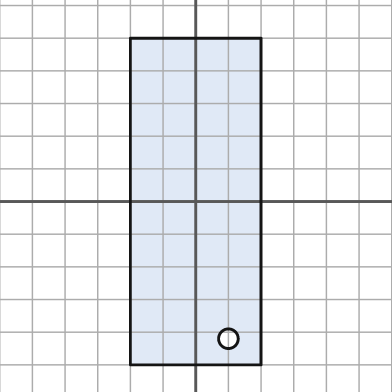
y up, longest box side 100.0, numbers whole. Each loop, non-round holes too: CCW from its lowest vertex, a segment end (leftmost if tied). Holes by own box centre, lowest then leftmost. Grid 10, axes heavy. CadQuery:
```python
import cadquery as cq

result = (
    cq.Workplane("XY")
    .moveTo(-20.0, -50.0)
    .lineTo(20.0, -50.0)
    .lineTo(20.0, 50.0)
    .lineTo(-20.0, 50.0)
    .close()
    .moveTo(10.0, -42.0)
    .circle(3.0)
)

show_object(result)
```